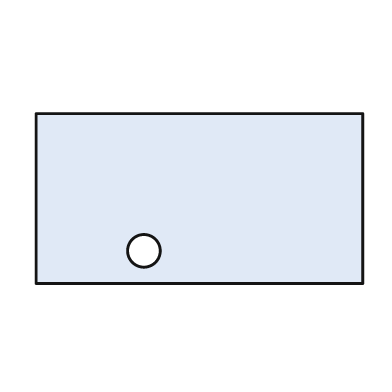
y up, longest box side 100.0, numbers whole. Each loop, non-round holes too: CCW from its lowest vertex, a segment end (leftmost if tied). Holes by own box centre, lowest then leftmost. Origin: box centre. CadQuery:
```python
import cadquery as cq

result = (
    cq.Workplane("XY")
    .moveTo(-50.0, -26.0)
    .lineTo(50.0, -26.0)
    .lineTo(50.0, 26.0)
    .lineTo(-50.0, 26.0)
    .close()
    .moveTo(-17.0, -16.0)
    .circle(5.0)
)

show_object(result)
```